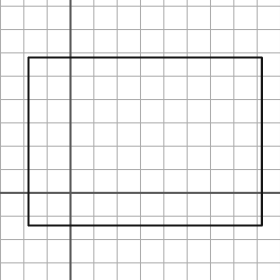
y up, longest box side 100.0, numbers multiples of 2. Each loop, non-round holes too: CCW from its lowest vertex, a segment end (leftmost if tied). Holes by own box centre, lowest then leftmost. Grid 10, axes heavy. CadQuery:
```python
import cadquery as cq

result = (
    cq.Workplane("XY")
    .moveTo(-18.0, -14.0)
    .lineTo(82.0, -14.0)
    .lineTo(82.0, 58.0)
    .lineTo(-18.0, 58.0)
    .close()
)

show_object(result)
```